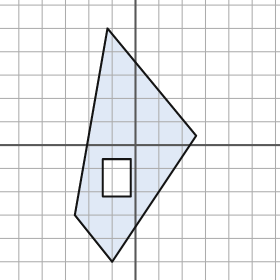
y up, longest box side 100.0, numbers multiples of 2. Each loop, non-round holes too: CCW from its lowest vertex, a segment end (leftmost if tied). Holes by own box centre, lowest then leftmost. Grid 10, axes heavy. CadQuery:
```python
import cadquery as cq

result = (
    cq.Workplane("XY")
    .moveTo(-10.0, -50.0)
    .lineTo(26.0, 4.0)
    .lineTo(-12.0, 50.0)
    .lineTo(-26.0, -30.0)
    .close()
    .moveTo(-14.0, -22.0)
    .lineTo(-2.0, -22.0)
    .lineTo(-2.0, -6.0)
    .lineTo(-14.0, -6.0)
    .close()
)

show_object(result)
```